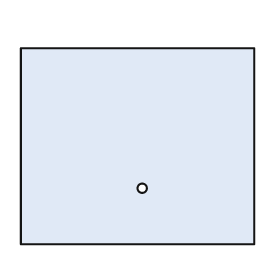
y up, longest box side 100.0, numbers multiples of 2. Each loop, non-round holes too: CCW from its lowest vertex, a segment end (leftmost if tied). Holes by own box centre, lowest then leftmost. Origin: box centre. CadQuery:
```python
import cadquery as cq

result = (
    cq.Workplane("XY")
    .moveTo(-50.0, -42.0)
    .lineTo(50.0, -42.0)
    .lineTo(50.0, 42.0)
    .lineTo(-50.0, 42.0)
    .close()
    .moveTo(2.0, -18.0)
    .circle(2.0)
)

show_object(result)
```